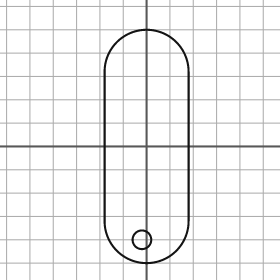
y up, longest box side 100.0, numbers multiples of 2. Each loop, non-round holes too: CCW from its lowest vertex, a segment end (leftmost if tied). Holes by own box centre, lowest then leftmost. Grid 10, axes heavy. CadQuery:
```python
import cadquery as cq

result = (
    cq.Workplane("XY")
    .moveTo(-18.0, -32.0)
    .threePointArc((0.0, -50.0), (18.0, -32.0))
    .lineTo(18.0, 32.0)
    .threePointArc((0.0, 50.0), (-18.0, 32.0))
    .close()
    .moveTo(-2.0, -40.0)
    .circle(4.0)
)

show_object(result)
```